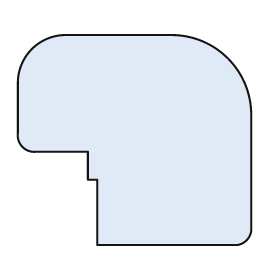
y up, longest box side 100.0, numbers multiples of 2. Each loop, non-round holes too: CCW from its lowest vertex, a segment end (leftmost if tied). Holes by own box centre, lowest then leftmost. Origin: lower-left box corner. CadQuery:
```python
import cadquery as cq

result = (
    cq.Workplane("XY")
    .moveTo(34.0, 0.0)
    .lineTo(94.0, 0.0)
    .threePointArc((98.0, 2.0), (100.0, 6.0))
    .lineTo(100.0, 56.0)
    .threePointArc((90.0, 80.0), (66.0, 90.0))
    .lineTo(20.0, 90.0)
    .threePointArc((6.0, 84.0), (0.0, 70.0))
    .lineTo(0.0, 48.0)
    .threePointArc((2.0, 42.0), (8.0, 40.0))
    .lineTo(30.0, 40.0)
    .lineTo(30.0, 28.0)
    .lineTo(34.0, 28.0)
    .close()
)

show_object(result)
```